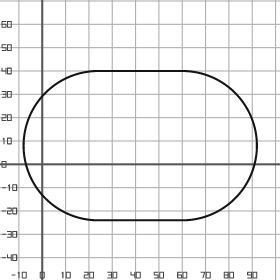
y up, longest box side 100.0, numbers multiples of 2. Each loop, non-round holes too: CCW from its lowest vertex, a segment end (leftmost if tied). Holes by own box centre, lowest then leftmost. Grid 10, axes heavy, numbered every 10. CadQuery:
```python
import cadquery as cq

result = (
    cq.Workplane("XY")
    .moveTo(24.0, -24.0)
    .lineTo(60.0, -24.0)
    .threePointArc((92.0, 8.0), (60.0, 40.0))
    .lineTo(24.0, 40.0)
    .threePointArc((-8.0, 8.0), (24.0, -24.0))
    .close()
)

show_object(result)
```